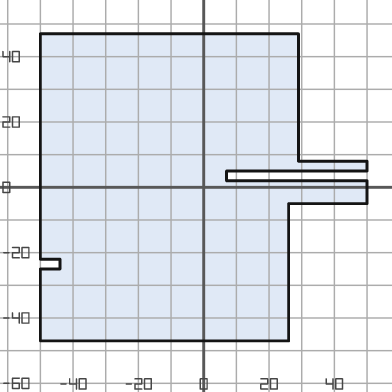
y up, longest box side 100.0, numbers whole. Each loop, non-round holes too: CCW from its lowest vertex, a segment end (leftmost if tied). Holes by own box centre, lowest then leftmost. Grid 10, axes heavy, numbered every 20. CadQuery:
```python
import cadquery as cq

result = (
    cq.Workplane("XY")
    .moveTo(-50.0, -47.0)
    .lineTo(26.0, -47.0)
    .lineTo(26.0, -5.0)
    .lineTo(50.0, -5.0)
    .lineTo(50.0, 2.0)
    .lineTo(7.0, 2.0)
    .lineTo(7.0, 5.0)
    .lineTo(50.0, 5.0)
    .lineTo(50.0, 8.0)
    .lineTo(29.0, 8.0)
    .lineTo(29.0, 47.0)
    .lineTo(-50.0, 47.0)
    .lineTo(-50.0, -22.0)
    .lineTo(-44.0, -22.0)
    .lineTo(-44.0, -25.0)
    .lineTo(-50.0, -25.0)
    .close()
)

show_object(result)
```